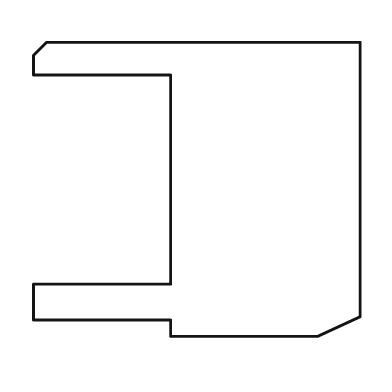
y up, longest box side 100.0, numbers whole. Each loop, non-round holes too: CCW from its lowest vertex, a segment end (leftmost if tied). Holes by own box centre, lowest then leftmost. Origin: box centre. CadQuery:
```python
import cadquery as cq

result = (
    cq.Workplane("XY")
    .moveTo(-8.0, -45.0)
    .lineTo(37.0, -45.0)
    .lineTo(50.0, -39.0)
    .lineTo(50.0, 45.0)
    .lineTo(-46.0, 45.0)
    .lineTo(-50.0, 41.0)
    .lineTo(-50.0, 35.0)
    .lineTo(-8.0, 35.0)
    .lineTo(-8.0, -29.0)
    .lineTo(-50.0, -29.0)
    .lineTo(-50.0, -40.0)
    .lineTo(-8.0, -40.0)
    .close()
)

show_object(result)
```